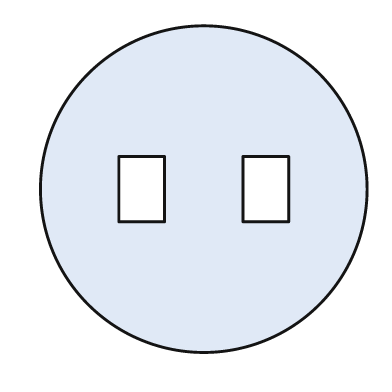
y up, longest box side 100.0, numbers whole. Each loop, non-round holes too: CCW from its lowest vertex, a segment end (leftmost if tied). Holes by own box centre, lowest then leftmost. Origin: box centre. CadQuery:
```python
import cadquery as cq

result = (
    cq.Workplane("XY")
    .moveTo(0.0, 0.0)
    .circle(50.0)
    .moveTo(-26.0, -10.0)
    .lineTo(-12.0, -10.0)
    .lineTo(-12.0, 10.0)
    .lineTo(-26.0, 10.0)
    .close()
    .moveTo(12.0, -10.0)
    .lineTo(26.0, -10.0)
    .lineTo(26.0, 10.0)
    .lineTo(12.0, 10.0)
    .close()
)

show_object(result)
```